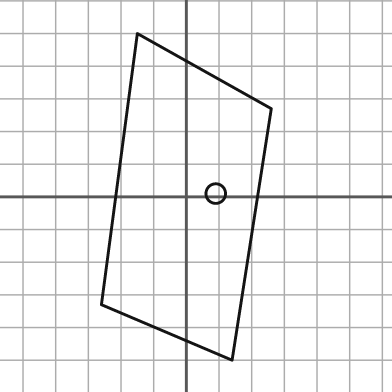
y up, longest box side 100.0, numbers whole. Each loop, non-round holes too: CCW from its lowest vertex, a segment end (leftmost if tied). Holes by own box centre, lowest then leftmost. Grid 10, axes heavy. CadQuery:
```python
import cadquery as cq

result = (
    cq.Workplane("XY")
    .moveTo(14.0, -50.0)
    .lineTo(26.0, 27.0)
    .lineTo(-15.0, 50.0)
    .lineTo(-26.0, -33.0)
    .close()
    .moveTo(9.0, 1.0)
    .circle(3.0)
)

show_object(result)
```